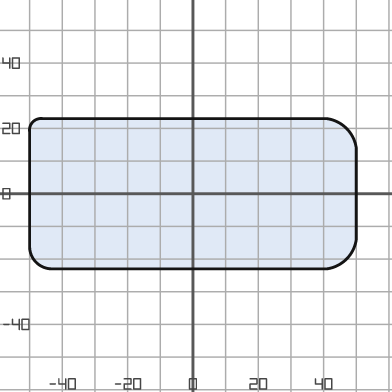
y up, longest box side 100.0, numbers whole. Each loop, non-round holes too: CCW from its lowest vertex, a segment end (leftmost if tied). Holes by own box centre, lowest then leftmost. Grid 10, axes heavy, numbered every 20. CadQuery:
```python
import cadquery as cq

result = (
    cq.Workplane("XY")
    .moveTo(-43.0, -23.0)
    .lineTo(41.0, -23.0)
    .threePointArc((47.0, -20.0), (50.0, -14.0))
    .lineTo(50.0, 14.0)
    .threePointArc((47.0, 20.0), (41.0, 23.0))
    .lineTo(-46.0, 23.0)
    .threePointArc((-49.0, 22.0), (-50.0, 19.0))
    .lineTo(-50.0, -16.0)
    .threePointArc((-48.0, -21.0), (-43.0, -23.0))
    .close()
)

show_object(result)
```